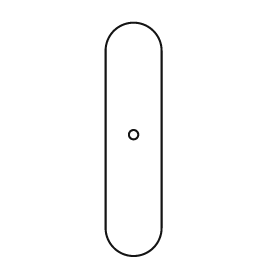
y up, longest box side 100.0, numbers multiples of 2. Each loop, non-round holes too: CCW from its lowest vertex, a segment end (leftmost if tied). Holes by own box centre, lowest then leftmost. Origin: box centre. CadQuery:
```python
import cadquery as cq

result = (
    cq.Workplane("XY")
    .moveTo(-12.0, -38.0)
    .threePointArc((0.0, -50.0), (12.0, -38.0))
    .lineTo(12.0, 38.0)
    .threePointArc((0.0, 50.0), (-12.0, 38.0))
    .close()
    .moveTo(0.0, 2.0)
    .circle(2.0)
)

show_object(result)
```